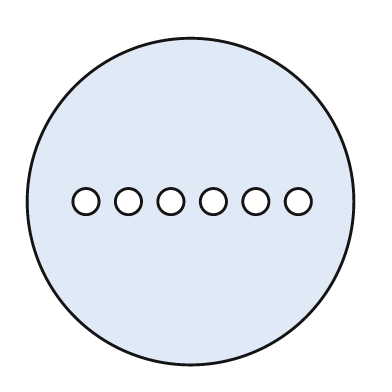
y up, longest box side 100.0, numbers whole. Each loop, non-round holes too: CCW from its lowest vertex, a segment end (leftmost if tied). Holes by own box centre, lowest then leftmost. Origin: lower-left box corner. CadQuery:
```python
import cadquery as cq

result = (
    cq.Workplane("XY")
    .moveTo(50.0, 50.0)
    .circle(50.0)
    .moveTo(18.0, 50.0)
    .circle(4.0)
    .moveTo(31.0, 50.0)
    .circle(4.0)
    .moveTo(44.0, 50.0)
    .circle(4.0)
    .moveTo(57.0, 50.0)
    .circle(4.0)
    .moveTo(70.0, 50.0)
    .circle(4.0)
    .moveTo(83.0, 50.0)
    .circle(4.0)
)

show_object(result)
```